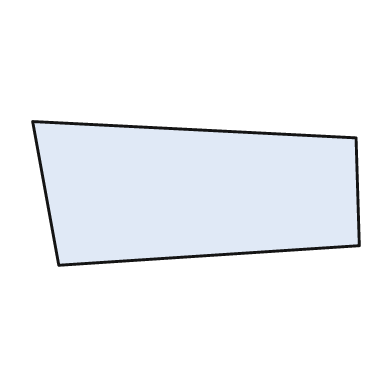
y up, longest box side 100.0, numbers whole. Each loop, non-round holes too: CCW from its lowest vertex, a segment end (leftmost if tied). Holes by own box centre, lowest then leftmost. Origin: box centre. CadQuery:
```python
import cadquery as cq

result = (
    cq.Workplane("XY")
    .moveTo(-42.0, -22.0)
    .lineTo(50.0, -16.0)
    .lineTo(49.0, 17.0)
    .lineTo(-50.0, 22.0)
    .close()
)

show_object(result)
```